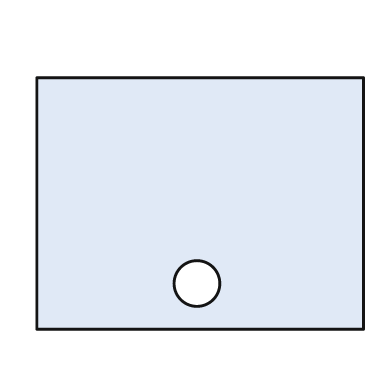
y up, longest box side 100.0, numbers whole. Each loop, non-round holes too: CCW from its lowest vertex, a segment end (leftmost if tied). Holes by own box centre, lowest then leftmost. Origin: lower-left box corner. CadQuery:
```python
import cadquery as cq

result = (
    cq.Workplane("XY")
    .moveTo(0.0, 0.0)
    .lineTo(100.0, 0.0)
    .lineTo(100.0, 77.0)
    .lineTo(0.0, 77.0)
    .close()
    .moveTo(49.0, 14.0)
    .circle(7.0)
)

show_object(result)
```